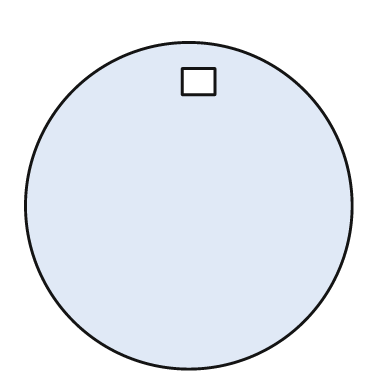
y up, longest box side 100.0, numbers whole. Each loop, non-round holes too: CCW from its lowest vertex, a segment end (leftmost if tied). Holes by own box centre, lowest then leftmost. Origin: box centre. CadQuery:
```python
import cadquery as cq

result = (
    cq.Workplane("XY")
    .moveTo(0.0, 0.0)
    .circle(50.0)
    .moveTo(-2.0, 34.0)
    .lineTo(8.0, 34.0)
    .lineTo(8.0, 42.0)
    .lineTo(-2.0, 42.0)
    .close()
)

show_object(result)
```